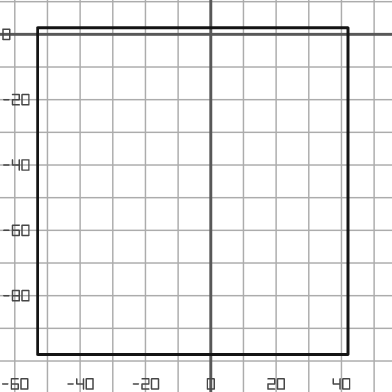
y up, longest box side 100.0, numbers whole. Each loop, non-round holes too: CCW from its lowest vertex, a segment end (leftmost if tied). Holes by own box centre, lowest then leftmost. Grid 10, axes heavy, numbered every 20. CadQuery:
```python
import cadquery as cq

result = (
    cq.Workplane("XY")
    .moveTo(-53.0, -98.0)
    .lineTo(42.0, -98.0)
    .lineTo(42.0, 2.0)
    .lineTo(-53.0, 2.0)
    .close()
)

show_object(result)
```